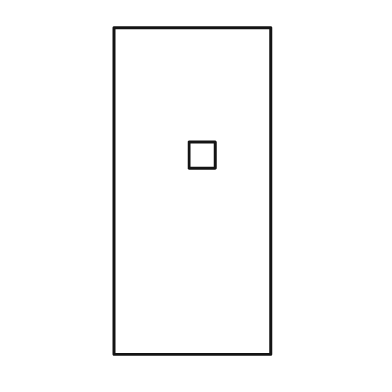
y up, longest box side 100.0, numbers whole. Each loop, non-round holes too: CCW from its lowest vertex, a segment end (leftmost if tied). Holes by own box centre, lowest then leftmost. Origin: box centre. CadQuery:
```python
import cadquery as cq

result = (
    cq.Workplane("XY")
    .moveTo(-24.0, -50.0)
    .lineTo(24.0, -50.0)
    .lineTo(24.0, 50.0)
    .lineTo(-24.0, 50.0)
    .close()
    .moveTo(-1.0, 7.0)
    .lineTo(7.0, 7.0)
    .lineTo(7.0, 15.0)
    .lineTo(-1.0, 15.0)
    .close()
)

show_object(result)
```